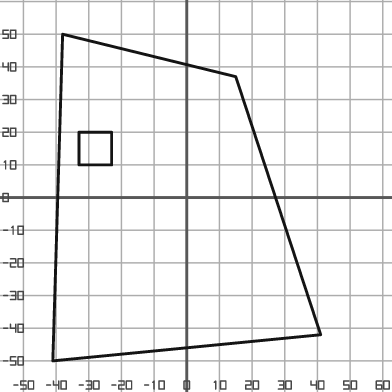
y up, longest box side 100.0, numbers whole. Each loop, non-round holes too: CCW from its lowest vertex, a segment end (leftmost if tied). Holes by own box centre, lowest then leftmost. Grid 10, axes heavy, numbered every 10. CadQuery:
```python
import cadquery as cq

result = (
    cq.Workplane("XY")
    .moveTo(-41.0, -50.0)
    .lineTo(41.0, -42.0)
    .lineTo(15.0, 37.0)
    .lineTo(-38.0, 50.0)
    .close()
    .moveTo(-33.0, 10.0)
    .lineTo(-23.0, 10.0)
    .lineTo(-23.0, 20.0)
    .lineTo(-33.0, 20.0)
    .close()
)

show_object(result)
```